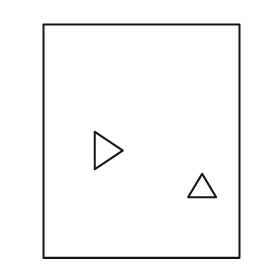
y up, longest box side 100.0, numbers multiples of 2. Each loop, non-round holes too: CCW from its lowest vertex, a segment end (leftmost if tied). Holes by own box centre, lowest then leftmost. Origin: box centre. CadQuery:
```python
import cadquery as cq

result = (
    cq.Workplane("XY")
    .moveTo(-42.0, -50.0)
    .lineTo(42.0, -50.0)
    .lineTo(42.0, 50.0)
    .lineTo(-42.0, 50.0)
    .close()
    .moveTo(20.0, -24.0)
    .lineTo(32.0, -24.0)
    .lineTo(26.0, -14.0)
    .close()
    .moveTo(-20.0, -12.0)
    .lineTo(-8.0, -4.0)
    .lineTo(-20.0, 4.0)
    .close()
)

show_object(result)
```